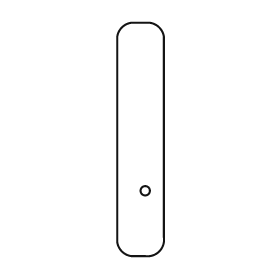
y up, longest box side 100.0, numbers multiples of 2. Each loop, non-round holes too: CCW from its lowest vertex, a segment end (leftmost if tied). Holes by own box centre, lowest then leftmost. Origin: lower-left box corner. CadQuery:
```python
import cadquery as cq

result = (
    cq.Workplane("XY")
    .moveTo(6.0, 0.0)
    .lineTo(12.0, 0.0)
    .threePointArc((18.0, 2.0), (20.0, 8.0))
    .lineTo(20.0, 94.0)
    .threePointArc((18.0, 98.0), (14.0, 100.0))
    .lineTo(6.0, 100.0)
    .threePointArc((2.0, 98.0), (0.0, 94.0))
    .lineTo(0.0, 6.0)
    .threePointArc((2.0, 2.0), (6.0, 0.0))
    .close()
    .moveTo(12.0, 28.0)
    .circle(2.0)
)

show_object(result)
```